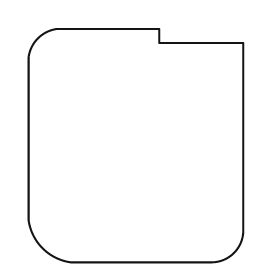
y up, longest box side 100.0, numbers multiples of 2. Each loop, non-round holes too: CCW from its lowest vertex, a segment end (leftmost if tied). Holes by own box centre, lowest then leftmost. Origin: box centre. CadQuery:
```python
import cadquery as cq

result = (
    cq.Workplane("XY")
    .moveTo(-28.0, -50.0)
    .lineTo(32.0, -50.0)
    .threePointArc((42.0, -46.0), (46.0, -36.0))
    .lineTo(46.0, 44.0)
    .lineTo(10.0, 44.0)
    .lineTo(10.0, 50.0)
    .lineTo(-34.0, 50.0)
    .threePointArc((-42.0, 46.0), (-46.0, 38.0))
    .lineTo(-46.0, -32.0)
    .threePointArc((-40.0, -44.0), (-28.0, -50.0))
    .close()
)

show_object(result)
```